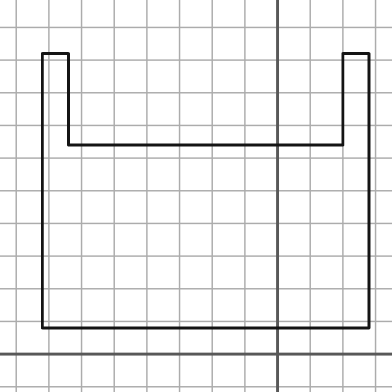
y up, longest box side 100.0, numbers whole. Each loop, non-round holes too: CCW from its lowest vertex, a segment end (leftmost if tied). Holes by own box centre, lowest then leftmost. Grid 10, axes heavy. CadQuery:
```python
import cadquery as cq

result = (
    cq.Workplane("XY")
    .moveTo(-72.0, 8.0)
    .lineTo(28.0, 8.0)
    .lineTo(28.0, 92.0)
    .lineTo(20.0, 92.0)
    .lineTo(20.0, 64.0)
    .lineTo(-64.0, 64.0)
    .lineTo(-64.0, 92.0)
    .lineTo(-72.0, 92.0)
    .close()
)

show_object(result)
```